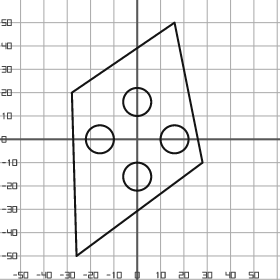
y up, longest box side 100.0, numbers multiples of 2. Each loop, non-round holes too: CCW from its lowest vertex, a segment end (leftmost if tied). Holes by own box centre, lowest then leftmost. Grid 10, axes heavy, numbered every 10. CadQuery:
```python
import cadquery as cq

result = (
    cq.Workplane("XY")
    .moveTo(-26.0, -50.0)
    .lineTo(28.0, -10.0)
    .lineTo(16.0, 50.0)
    .lineTo(-28.0, 20.0)
    .close()
    .moveTo(0.0, -16.0)
    .circle(6.0)
    .moveTo(-16.0, 0.0)
    .circle(6.0)
    .moveTo(16.0, 0.0)
    .circle(6.0)
    .moveTo(0.0, 16.0)
    .circle(6.0)
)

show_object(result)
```